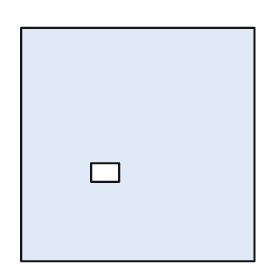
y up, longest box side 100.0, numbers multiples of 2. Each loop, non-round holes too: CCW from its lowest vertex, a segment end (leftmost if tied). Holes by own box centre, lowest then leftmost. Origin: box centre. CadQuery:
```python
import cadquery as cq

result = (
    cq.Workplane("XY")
    .moveTo(-50.0, -50.0)
    .lineTo(50.0, -50.0)
    .lineTo(50.0, 50.0)
    .lineTo(-50.0, 50.0)
    .close()
    .moveTo(-20.0, -16.0)
    .lineTo(-8.0, -16.0)
    .lineTo(-8.0, -8.0)
    .lineTo(-20.0, -8.0)
    .close()
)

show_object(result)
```